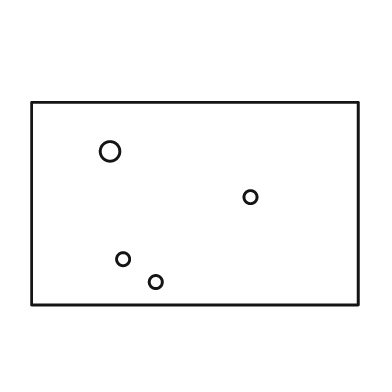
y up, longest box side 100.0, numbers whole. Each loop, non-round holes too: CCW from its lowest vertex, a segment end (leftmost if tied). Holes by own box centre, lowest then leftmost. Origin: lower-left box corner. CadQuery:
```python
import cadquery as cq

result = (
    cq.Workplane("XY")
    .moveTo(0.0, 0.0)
    .lineTo(100.0, 0.0)
    .lineTo(100.0, 62.0)
    .lineTo(0.0, 62.0)
    .close()
    .moveTo(38.0, 7.0)
    .circle(2.0)
    .moveTo(28.0, 14.0)
    .circle(2.0)
    .moveTo(67.0, 33.0)
    .circle(2.0)
    .moveTo(24.0, 47.0)
    .circle(3.0)
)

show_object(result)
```